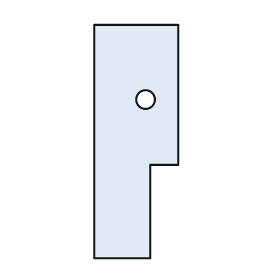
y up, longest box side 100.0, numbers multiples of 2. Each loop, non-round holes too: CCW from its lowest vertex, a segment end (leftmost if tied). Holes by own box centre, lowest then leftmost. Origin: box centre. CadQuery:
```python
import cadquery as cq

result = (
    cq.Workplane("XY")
    .moveTo(-18.0, -50.0)
    .lineTo(6.0, -50.0)
    .lineTo(6.0, -10.0)
    .lineTo(18.0, -10.0)
    .lineTo(18.0, 50.0)
    .lineTo(-18.0, 50.0)
    .close()
    .moveTo(4.0, 18.0)
    .circle(4.0)
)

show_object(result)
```